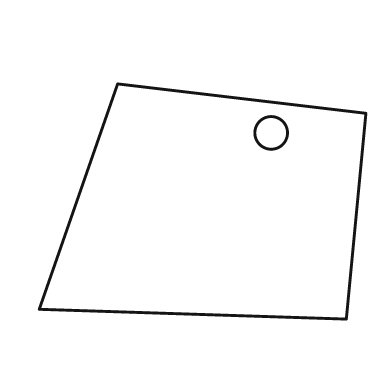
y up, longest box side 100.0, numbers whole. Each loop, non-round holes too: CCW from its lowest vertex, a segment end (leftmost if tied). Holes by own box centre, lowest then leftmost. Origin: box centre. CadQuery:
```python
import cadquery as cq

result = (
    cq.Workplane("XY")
    .moveTo(44.0, -36.0)
    .lineTo(50.0, 27.0)
    .lineTo(-26.0, 36.0)
    .lineTo(-50.0, -33.0)
    .close()
    .moveTo(21.0, 21.0)
    .circle(5.0)
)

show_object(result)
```